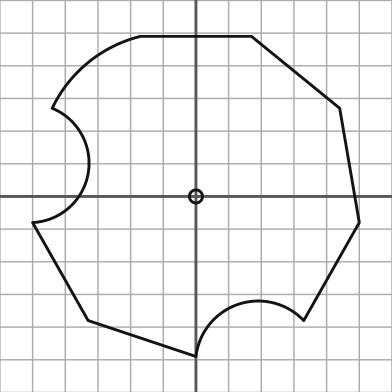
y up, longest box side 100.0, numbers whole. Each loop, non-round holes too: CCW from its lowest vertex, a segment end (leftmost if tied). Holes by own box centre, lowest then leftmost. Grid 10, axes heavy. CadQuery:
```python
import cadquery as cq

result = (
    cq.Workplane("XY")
    .moveTo(0.0, -49.0)
    .threePointArc((13.0, -33.0), (33.0, -38.0))
    .lineTo(50.0, -8.0)
    .lineTo(44.0, 27.0)
    .lineTo(17.0, 49.0)
    .lineTo(-17.0, 49.0)
    .threePointArc((-33.0, 41.0), (-44.0, 27.0))
    .threePointArc((-33.0, 7.0), (-50.0, -8.0))
    .lineTo(-33.0, -38.0)
    .close()
    .moveTo(0.0, 0.0)
    .circle(2.0)
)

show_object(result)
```